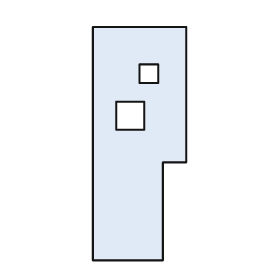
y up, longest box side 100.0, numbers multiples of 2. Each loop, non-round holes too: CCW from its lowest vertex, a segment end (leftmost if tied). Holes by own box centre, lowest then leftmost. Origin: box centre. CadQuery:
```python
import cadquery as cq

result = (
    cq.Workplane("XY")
    .moveTo(-20.0, -50.0)
    .lineTo(10.0, -50.0)
    .lineTo(10.0, -8.0)
    .lineTo(20.0, -8.0)
    .lineTo(20.0, 50.0)
    .lineTo(-20.0, 50.0)
    .close()
    .moveTo(-10.0, 6.0)
    .lineTo(2.0, 6.0)
    .lineTo(2.0, 18.0)
    .lineTo(-10.0, 18.0)
    .close()
    .moveTo(0.0, 26.0)
    .lineTo(8.0, 26.0)
    .lineTo(8.0, 34.0)
    .lineTo(0.0, 34.0)
    .close()
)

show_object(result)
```